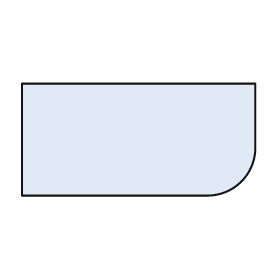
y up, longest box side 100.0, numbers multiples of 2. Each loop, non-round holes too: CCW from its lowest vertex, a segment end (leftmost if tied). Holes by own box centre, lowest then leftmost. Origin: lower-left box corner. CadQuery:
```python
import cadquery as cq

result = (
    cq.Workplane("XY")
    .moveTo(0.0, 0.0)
    .lineTo(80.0, 0.0)
    .threePointArc((94.0, 6.0), (100.0, 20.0))
    .lineTo(100.0, 48.0)
    .lineTo(0.0, 48.0)
    .close()
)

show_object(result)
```